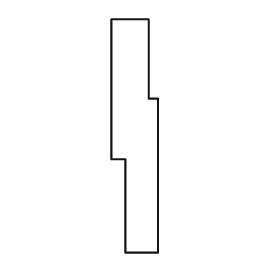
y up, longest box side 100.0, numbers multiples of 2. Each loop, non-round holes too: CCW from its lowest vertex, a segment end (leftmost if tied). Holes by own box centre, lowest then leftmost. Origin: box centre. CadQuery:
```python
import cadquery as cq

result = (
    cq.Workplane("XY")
    .moveTo(-4.0, -50.0)
    .lineTo(10.0, -50.0)
    .lineTo(10.0, 16.0)
    .lineTo(6.0, 16.0)
    .lineTo(6.0, 50.0)
    .lineTo(-10.0, 50.0)
    .lineTo(-10.0, -10.0)
    .lineTo(-4.0, -10.0)
    .close()
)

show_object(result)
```